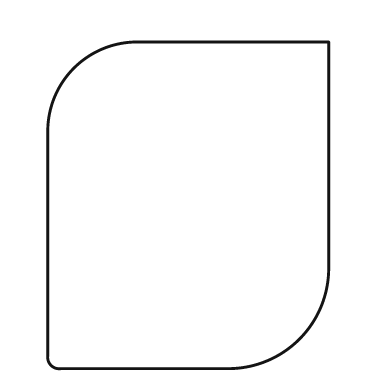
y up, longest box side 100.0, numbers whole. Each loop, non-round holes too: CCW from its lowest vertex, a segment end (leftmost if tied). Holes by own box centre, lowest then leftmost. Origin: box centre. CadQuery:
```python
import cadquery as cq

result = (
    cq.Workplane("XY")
    .moveTo(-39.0, -50.0)
    .lineTo(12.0, -50.0)
    .threePointArc((34.0, -41.0), (43.0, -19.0))
    .lineTo(43.0, 50.0)
    .lineTo(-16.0, 50.0)
    .threePointArc((-35.0, 42.0), (-43.0, 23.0))
    .lineTo(-43.0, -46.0)
    .threePointArc((-42.0, -49.0), (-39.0, -50.0))
    .close()
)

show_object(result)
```